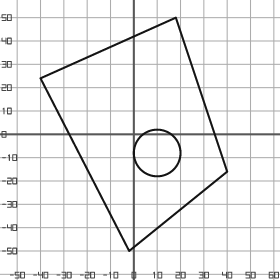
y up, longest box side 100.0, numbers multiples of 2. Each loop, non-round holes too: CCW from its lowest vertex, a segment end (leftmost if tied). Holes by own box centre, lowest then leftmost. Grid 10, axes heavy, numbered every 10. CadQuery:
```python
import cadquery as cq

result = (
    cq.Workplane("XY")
    .moveTo(-2.0, -50.0)
    .lineTo(40.0, -16.0)
    .lineTo(18.0, 50.0)
    .lineTo(-40.0, 24.0)
    .close()
    .moveTo(10.0, -8.0)
    .circle(10.0)
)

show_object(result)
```